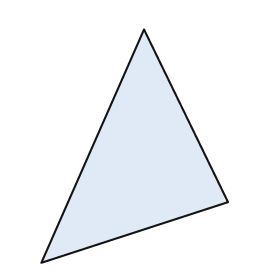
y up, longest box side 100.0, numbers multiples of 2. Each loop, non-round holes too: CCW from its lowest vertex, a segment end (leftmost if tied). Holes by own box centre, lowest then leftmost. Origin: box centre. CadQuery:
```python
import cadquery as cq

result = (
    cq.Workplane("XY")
    .moveTo(-40.0, -50.0)
    .lineTo(40.0, -24.0)
    .lineTo(4.0, 50.0)
    .close()
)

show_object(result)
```